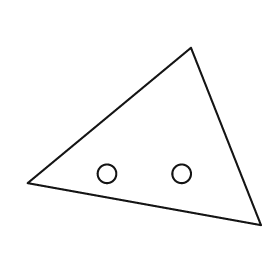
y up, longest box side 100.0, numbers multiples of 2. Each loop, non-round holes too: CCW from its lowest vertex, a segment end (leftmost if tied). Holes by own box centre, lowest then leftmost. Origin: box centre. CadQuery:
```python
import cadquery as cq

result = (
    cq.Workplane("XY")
    .moveTo(50.0, -38.0)
    .lineTo(20.0, 38.0)
    .lineTo(-50.0, -20.0)
    .close()
    .moveTo(-16.0, -16.0)
    .circle(4.0)
    .moveTo(16.0, -16.0)
    .circle(4.0)
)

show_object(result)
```